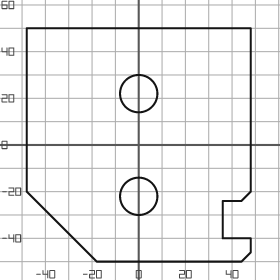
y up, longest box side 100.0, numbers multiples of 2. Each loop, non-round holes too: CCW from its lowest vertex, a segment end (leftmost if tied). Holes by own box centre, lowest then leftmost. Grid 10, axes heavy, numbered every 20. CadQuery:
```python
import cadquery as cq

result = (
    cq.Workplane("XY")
    .moveTo(-18.0, -50.0)
    .lineTo(44.0, -50.0)
    .lineTo(48.0, -46.0)
    .lineTo(48.0, -40.0)
    .lineTo(36.0, -40.0)
    .lineTo(36.0, -24.0)
    .lineTo(44.0, -24.0)
    .lineTo(48.0, -20.0)
    .lineTo(48.0, 50.0)
    .lineTo(-48.0, 50.0)
    .lineTo(-48.0, -20.0)
    .close()
    .moveTo(0.0, -22.0)
    .circle(8.0)
    .moveTo(0.0, 22.0)
    .circle(8.0)
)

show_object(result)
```